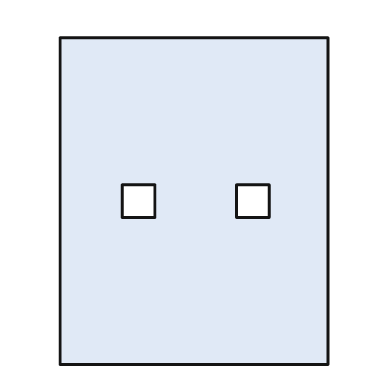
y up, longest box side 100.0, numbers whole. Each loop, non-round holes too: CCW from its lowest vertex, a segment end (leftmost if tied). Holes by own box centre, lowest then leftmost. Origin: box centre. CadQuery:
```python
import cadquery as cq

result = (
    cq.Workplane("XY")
    .moveTo(-41.0, -50.0)
    .lineTo(41.0, -50.0)
    .lineTo(41.0, 50.0)
    .lineTo(-41.0, 50.0)
    .close()
    .moveTo(-22.0, -5.0)
    .lineTo(-12.0, -5.0)
    .lineTo(-12.0, 5.0)
    .lineTo(-22.0, 5.0)
    .close()
    .moveTo(13.0, -5.0)
    .lineTo(23.0, -5.0)
    .lineTo(23.0, 5.0)
    .lineTo(13.0, 5.0)
    .close()
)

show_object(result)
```